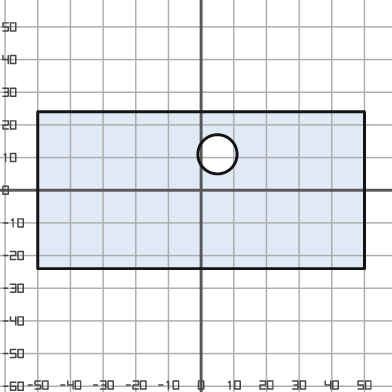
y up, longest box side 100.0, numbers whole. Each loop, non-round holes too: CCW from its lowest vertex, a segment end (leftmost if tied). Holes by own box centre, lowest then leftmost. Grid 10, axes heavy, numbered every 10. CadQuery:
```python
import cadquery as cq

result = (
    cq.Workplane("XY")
    .moveTo(-50.0, -24.0)
    .lineTo(50.0, -24.0)
    .lineTo(50.0, 24.0)
    .lineTo(-50.0, 24.0)
    .close()
    .moveTo(5.0, 11.0)
    .circle(6.0)
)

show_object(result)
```